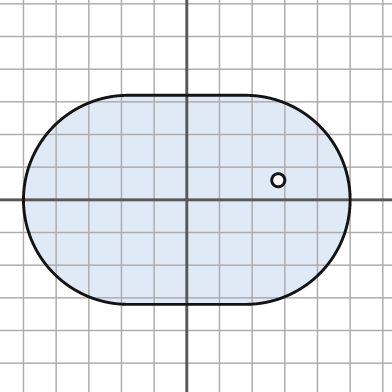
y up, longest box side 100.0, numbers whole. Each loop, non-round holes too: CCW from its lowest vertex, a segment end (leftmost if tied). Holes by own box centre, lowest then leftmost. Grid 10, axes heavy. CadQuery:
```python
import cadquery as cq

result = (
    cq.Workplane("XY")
    .moveTo(-18.0, -32.0)
    .lineTo(18.0, -32.0)
    .threePointArc((50.0, 0.0), (18.0, 32.0))
    .lineTo(-18.0, 32.0)
    .threePointArc((-50.0, 0.0), (-18.0, -32.0))
    .close()
    .moveTo(28.0, 6.0)
    .circle(2.0)
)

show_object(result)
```